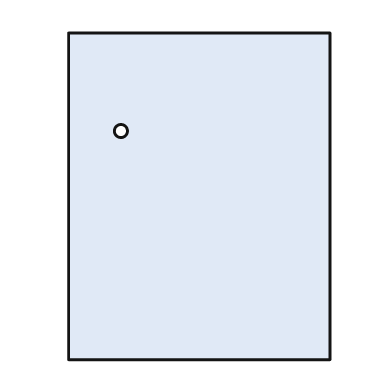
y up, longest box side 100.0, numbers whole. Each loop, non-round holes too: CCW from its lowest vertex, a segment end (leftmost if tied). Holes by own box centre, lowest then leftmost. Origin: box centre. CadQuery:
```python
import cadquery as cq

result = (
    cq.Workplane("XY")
    .moveTo(-40.0, -50.0)
    .lineTo(40.0, -50.0)
    .lineTo(40.0, 50.0)
    .lineTo(-40.0, 50.0)
    .close()
    .moveTo(-24.0, 20.0)
    .circle(2.0)
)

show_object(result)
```